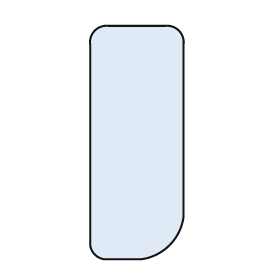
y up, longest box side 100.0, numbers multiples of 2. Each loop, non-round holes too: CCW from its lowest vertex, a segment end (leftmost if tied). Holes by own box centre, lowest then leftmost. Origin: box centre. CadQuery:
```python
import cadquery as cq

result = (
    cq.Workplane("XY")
    .moveTo(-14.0, -50.0)
    .lineTo(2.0, -50.0)
    .threePointArc((14.0, -44.0), (20.0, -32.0))
    .lineTo(20.0, 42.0)
    .threePointArc((18.0, 48.0), (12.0, 50.0))
    .lineTo(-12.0, 50.0)
    .threePointArc((-18.0, 48.0), (-20.0, 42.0))
    .lineTo(-20.0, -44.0)
    .threePointArc((-18.0, -48.0), (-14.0, -50.0))
    .close()
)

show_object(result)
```